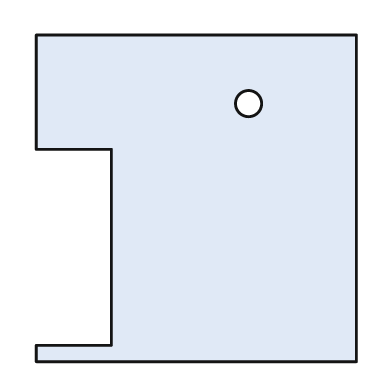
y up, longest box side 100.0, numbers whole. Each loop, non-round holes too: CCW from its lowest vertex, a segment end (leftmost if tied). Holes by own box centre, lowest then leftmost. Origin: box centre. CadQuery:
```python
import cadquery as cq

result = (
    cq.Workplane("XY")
    .moveTo(-49.0, -50.0)
    .lineTo(49.0, -50.0)
    .lineTo(49.0, 50.0)
    .lineTo(-49.0, 50.0)
    .lineTo(-49.0, 15.0)
    .lineTo(-26.0, 15.0)
    .lineTo(-26.0, -45.0)
    .lineTo(-49.0, -45.0)
    .close()
    .moveTo(16.0, 29.0)
    .circle(4.0)
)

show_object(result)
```